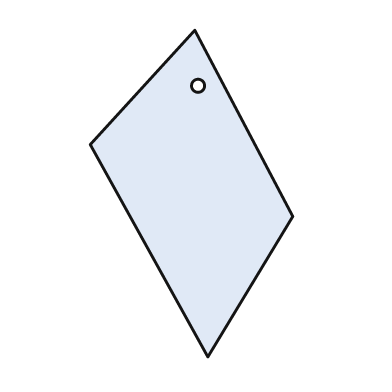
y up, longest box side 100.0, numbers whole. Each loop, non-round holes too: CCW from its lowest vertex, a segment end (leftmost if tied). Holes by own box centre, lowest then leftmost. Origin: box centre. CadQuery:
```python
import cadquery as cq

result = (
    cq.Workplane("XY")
    .moveTo(5.0, -50.0)
    .lineTo(31.0, -7.0)
    .lineTo(1.0, 50.0)
    .lineTo(-31.0, 15.0)
    .close()
    .moveTo(2.0, 33.0)
    .circle(2.0)
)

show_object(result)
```